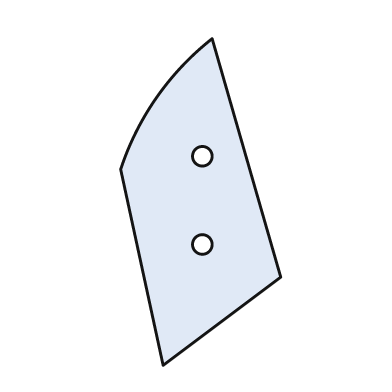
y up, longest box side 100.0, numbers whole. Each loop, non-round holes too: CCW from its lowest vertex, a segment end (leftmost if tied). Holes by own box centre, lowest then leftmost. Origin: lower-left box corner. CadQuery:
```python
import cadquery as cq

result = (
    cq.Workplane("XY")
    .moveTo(13.0, 0.0)
    .lineTo(49.0, 27.0)
    .lineTo(28.0, 100.0)
    .threePointArc((11.0, 82.0), (0.0, 60.0))
    .close()
    .moveTo(25.0, 37.0)
    .circle(3.0)
    .moveTo(25.0, 64.0)
    .circle(3.0)
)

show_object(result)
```